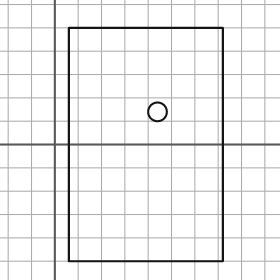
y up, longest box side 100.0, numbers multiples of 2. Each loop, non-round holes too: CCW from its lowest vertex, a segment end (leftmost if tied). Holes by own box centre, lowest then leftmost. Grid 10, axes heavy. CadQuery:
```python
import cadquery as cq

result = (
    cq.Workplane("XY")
    .moveTo(6.0, -50.0)
    .lineTo(72.0, -50.0)
    .lineTo(72.0, 50.0)
    .lineTo(6.0, 50.0)
    .close()
    .moveTo(44.0, 14.0)
    .circle(4.0)
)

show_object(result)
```